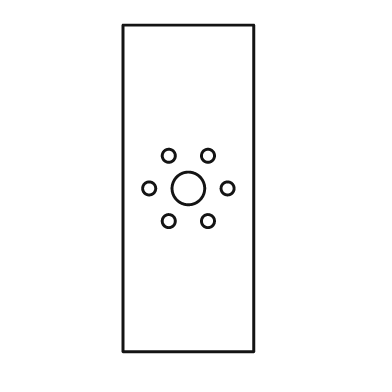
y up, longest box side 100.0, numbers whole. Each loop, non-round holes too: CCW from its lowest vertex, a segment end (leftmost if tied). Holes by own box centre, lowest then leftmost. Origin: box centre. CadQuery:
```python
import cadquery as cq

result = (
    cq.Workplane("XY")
    .moveTo(-20.0, -50.0)
    .lineTo(20.0, -50.0)
    .lineTo(20.0, 50.0)
    .lineTo(-20.0, 50.0)
    .close()
    .moveTo(-6.0, -10.0)
    .circle(2.0)
    .moveTo(6.0, -10.0)
    .circle(2.0)
    .moveTo(-12.0, 0.0)
    .circle(2.0)
    .moveTo(0.0, 0.0)
    .circle(5.0)
    .moveTo(12.0, 0.0)
    .circle(2.0)
    .moveTo(-6.0, 10.0)
    .circle(2.0)
    .moveTo(6.0, 10.0)
    .circle(2.0)
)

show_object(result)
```